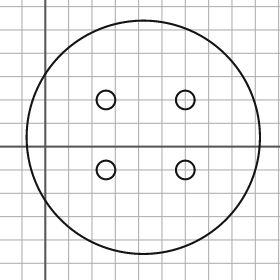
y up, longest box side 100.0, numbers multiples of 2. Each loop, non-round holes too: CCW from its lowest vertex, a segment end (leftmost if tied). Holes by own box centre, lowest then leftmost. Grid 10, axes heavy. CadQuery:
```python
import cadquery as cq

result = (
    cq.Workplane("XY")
    .moveTo(42.0, 4.0)
    .circle(50.0)
    .moveTo(26.0, -10.0)
    .circle(4.0)
    .moveTo(60.0, -10.0)
    .circle(4.0)
    .moveTo(26.0, 20.0)
    .circle(4.0)
    .moveTo(60.0, 20.0)
    .circle(4.0)
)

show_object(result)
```